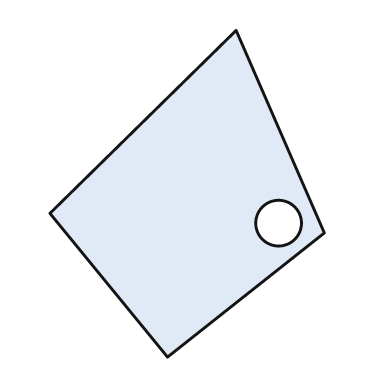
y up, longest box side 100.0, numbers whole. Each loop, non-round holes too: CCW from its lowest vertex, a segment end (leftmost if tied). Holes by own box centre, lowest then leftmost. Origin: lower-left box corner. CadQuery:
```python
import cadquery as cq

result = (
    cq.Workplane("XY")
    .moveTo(36.0, 0.0)
    .lineTo(84.0, 38.0)
    .lineTo(57.0, 100.0)
    .lineTo(0.0, 44.0)
    .close()
    .moveTo(70.0, 41.0)
    .circle(7.0)
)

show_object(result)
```